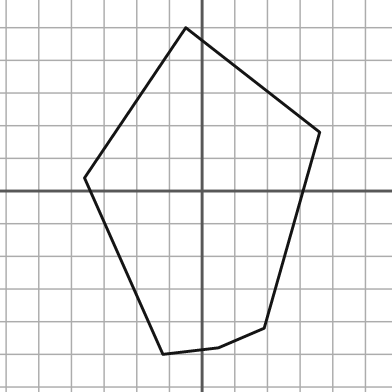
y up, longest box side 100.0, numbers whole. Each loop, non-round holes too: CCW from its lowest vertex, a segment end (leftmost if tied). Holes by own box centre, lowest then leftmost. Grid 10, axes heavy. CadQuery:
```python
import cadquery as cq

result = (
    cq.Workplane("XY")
    .moveTo(-12.0, -50.0)
    .lineTo(5.0, -48.0)
    .lineTo(19.0, -42.0)
    .lineTo(36.0, 18.0)
    .lineTo(-5.0, 50.0)
    .lineTo(-36.0, 4.0)
    .close()
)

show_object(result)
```